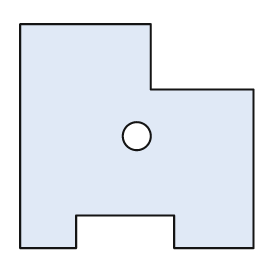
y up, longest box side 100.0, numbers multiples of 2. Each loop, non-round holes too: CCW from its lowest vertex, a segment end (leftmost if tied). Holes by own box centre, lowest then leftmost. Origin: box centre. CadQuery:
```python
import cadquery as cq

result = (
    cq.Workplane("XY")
    .moveTo(-50.0, -48.0)
    .lineTo(-26.0, -48.0)
    .lineTo(-26.0, -34.0)
    .lineTo(16.0, -34.0)
    .lineTo(16.0, -48.0)
    .lineTo(50.0, -48.0)
    .lineTo(50.0, 20.0)
    .lineTo(6.0, 20.0)
    .lineTo(6.0, 48.0)
    .lineTo(-50.0, 48.0)
    .close()
    .moveTo(0.0, 0.0)
    .circle(6.0)
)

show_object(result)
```